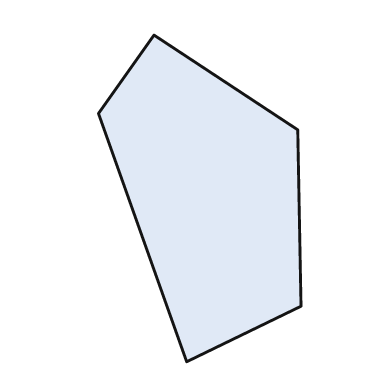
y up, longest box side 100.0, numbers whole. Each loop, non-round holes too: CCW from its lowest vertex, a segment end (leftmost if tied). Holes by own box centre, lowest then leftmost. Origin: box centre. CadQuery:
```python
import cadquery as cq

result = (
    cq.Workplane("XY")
    .moveTo(-4.0, -50.0)
    .lineTo(31.0, -33.0)
    .lineTo(30.0, 21.0)
    .lineTo(-14.0, 50.0)
    .lineTo(-31.0, 26.0)
    .close()
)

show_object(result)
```